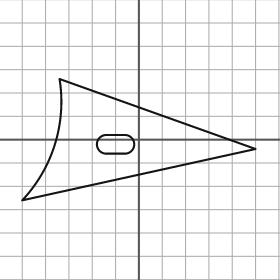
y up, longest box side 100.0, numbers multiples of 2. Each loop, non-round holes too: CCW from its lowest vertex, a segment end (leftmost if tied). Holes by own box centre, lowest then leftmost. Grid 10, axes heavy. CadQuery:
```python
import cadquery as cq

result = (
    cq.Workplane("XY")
    .moveTo(-50.0, -26.0)
    .lineTo(50.0, -4.0)
    .lineTo(-34.0, 26.0)
    .threePointArc((-36.0, -2.0), (-50.0, -26.0))
    .close()
    .moveTo(-14.0, -6.0)
    .lineTo(-6.0, -6.0)
    .threePointArc((-2.0, -2.0), (-6.0, 2.0))
    .lineTo(-14.0, 2.0)
    .threePointArc((-18.0, -2.0), (-14.0, -6.0))
    .close()
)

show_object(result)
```